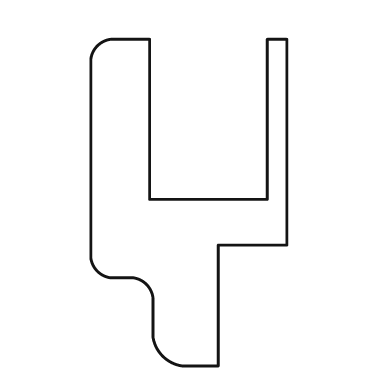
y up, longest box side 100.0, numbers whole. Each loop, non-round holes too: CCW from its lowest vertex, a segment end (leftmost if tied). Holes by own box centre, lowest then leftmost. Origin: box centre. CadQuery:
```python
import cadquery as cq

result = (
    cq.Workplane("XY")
    .moveTo(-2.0, -50.0)
    .lineTo(9.0, -50.0)
    .lineTo(9.0, -13.0)
    .lineTo(30.0, -13.0)
    .lineTo(30.0, 50.0)
    .lineTo(24.0, 50.0)
    .lineTo(24.0, 1.0)
    .lineTo(-12.0, 1.0)
    .lineTo(-12.0, 50.0)
    .lineTo(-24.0, 50.0)
    .threePointArc((-28.0, 48.0), (-30.0, 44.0))
    .lineTo(-30.0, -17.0)
    .threePointArc((-28.0, -21.0), (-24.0, -23.0))
    .lineTo(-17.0, -23.0)
    .threePointArc((-13.0, -25.0), (-11.0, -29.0))
    .lineTo(-11.0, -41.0)
    .threePointArc((-8.0, -47.0), (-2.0, -50.0))
    .close()
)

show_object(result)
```